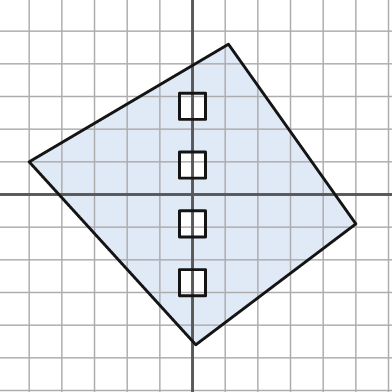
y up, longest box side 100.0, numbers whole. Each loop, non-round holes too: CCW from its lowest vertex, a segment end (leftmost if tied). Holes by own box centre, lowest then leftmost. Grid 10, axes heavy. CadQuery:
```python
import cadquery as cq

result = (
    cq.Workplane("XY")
    .moveTo(1.0, -46.0)
    .lineTo(50.0, -9.0)
    .lineTo(11.0, 46.0)
    .lineTo(-50.0, 10.0)
    .close()
    .moveTo(-4.0, -31.0)
    .lineTo(4.0, -31.0)
    .lineTo(4.0, -23.0)
    .lineTo(-4.0, -23.0)
    .close()
    .moveTo(-4.0, -13.0)
    .lineTo(4.0, -13.0)
    .lineTo(4.0, -5.0)
    .lineTo(-4.0, -5.0)
    .close()
    .moveTo(-4.0, 5.0)
    .lineTo(4.0, 5.0)
    .lineTo(4.0, 13.0)
    .lineTo(-4.0, 13.0)
    .close()
    .moveTo(-4.0, 23.0)
    .lineTo(4.0, 23.0)
    .lineTo(4.0, 31.0)
    .lineTo(-4.0, 31.0)
    .close()
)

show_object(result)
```